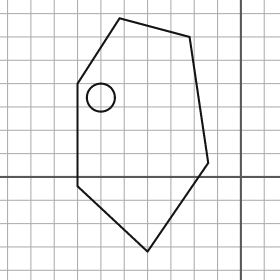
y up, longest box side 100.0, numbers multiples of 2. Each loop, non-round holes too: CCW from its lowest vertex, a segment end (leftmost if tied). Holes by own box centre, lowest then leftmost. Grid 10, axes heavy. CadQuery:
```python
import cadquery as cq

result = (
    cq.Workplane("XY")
    .moveTo(-40.0, -32.0)
    .lineTo(-14.0, 6.0)
    .lineTo(-22.0, 60.0)
    .lineTo(-52.0, 68.0)
    .lineTo(-70.0, 40.0)
    .lineTo(-70.0, -4.0)
    .close()
    .moveTo(-60.0, 34.0)
    .circle(6.0)
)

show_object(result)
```